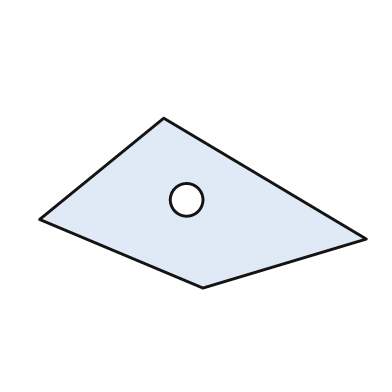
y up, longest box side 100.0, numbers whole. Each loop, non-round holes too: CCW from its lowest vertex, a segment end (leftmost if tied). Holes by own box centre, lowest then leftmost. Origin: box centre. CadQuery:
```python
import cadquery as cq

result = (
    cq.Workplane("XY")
    .moveTo(0.0, -26.0)
    .lineTo(50.0, -11.0)
    .lineTo(-12.0, 26.0)
    .lineTo(-50.0, -5.0)
    .close()
    .moveTo(-5.0, 1.0)
    .circle(5.0)
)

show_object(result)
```